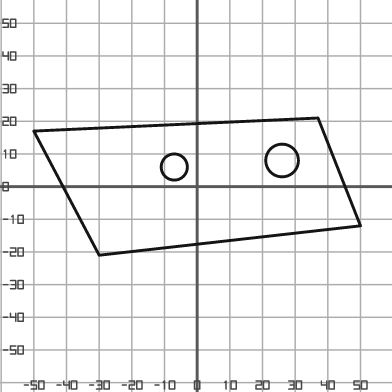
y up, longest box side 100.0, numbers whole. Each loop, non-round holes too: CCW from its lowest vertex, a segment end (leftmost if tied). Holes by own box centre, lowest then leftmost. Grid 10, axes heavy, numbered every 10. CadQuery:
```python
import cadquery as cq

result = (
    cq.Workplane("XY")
    .moveTo(-30.0, -21.0)
    .lineTo(50.0, -12.0)
    .lineTo(37.0, 21.0)
    .lineTo(-50.0, 17.0)
    .close()
    .moveTo(-7.0, 6.0)
    .circle(4.0)
    .moveTo(26.0, 8.0)
    .circle(5.0)
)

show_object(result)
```